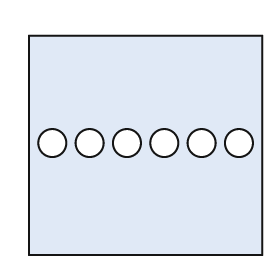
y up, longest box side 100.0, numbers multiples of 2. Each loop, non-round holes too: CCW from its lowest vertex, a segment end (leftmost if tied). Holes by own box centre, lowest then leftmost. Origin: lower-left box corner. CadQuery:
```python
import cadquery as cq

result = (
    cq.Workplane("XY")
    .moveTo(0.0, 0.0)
    .lineTo(100.0, 0.0)
    .lineTo(100.0, 94.0)
    .lineTo(0.0, 94.0)
    .close()
    .moveTo(10.0, 48.0)
    .circle(6.0)
    .moveTo(26.0, 48.0)
    .circle(6.0)
    .moveTo(42.0, 48.0)
    .circle(6.0)
    .moveTo(58.0, 48.0)
    .circle(6.0)
    .moveTo(74.0, 48.0)
    .circle(6.0)
    .moveTo(90.0, 48.0)
    .circle(6.0)
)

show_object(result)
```